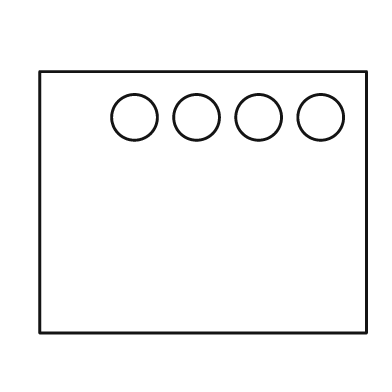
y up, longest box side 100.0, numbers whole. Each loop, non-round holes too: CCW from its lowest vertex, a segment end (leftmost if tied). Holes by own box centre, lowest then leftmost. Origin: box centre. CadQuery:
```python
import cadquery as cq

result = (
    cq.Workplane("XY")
    .moveTo(-50.0, -40.0)
    .lineTo(50.0, -40.0)
    .lineTo(50.0, 40.0)
    .lineTo(-50.0, 40.0)
    .close()
    .moveTo(-21.0, 26.0)
    .circle(7.0)
    .moveTo(-2.0, 26.0)
    .circle(7.0)
    .moveTo(17.0, 26.0)
    .circle(7.0)
    .moveTo(36.0, 26.0)
    .circle(7.0)
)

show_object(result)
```